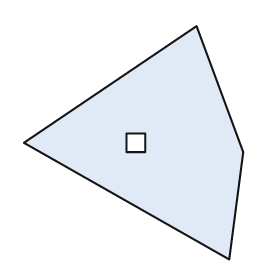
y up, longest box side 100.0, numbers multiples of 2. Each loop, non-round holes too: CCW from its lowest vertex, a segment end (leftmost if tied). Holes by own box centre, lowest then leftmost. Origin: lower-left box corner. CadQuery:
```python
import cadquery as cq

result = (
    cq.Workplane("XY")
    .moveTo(88.0, 0.0)
    .lineTo(94.0, 46.0)
    .lineTo(74.0, 100.0)
    .lineTo(0.0, 50.0)
    .close()
    .moveTo(44.0, 46.0)
    .lineTo(52.0, 46.0)
    .lineTo(52.0, 54.0)
    .lineTo(44.0, 54.0)
    .close()
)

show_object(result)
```